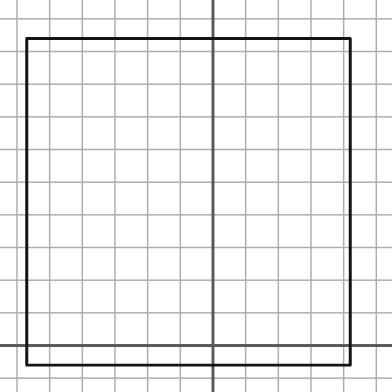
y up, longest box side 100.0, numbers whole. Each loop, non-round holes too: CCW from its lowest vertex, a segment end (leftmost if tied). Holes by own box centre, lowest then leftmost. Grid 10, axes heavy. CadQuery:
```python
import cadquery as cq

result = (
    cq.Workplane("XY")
    .moveTo(-57.0, -6.0)
    .lineTo(42.0, -6.0)
    .lineTo(42.0, 94.0)
    .lineTo(-57.0, 94.0)
    .close()
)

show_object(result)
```